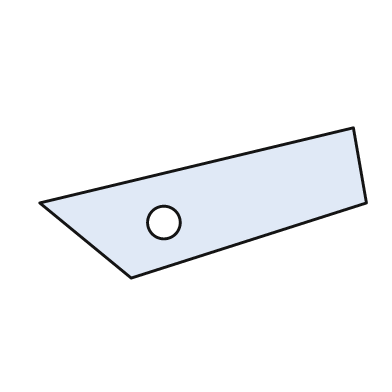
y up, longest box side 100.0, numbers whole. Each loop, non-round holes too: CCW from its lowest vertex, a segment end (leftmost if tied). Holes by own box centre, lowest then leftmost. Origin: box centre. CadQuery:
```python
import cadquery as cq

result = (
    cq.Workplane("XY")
    .moveTo(-22.0, -23.0)
    .lineTo(50.0, 0.0)
    .lineTo(46.0, 23.0)
    .lineTo(-50.0, 0.0)
    .close()
    .moveTo(-12.0, -6.0)
    .circle(5.0)
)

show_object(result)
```